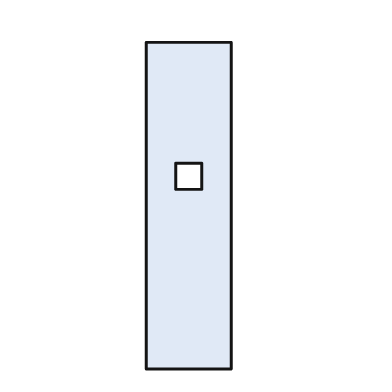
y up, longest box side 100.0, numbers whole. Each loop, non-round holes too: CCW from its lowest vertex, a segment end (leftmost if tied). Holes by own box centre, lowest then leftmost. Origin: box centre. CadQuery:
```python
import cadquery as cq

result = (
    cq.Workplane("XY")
    .moveTo(-13.0, -50.0)
    .lineTo(13.0, -50.0)
    .lineTo(13.0, 50.0)
    .lineTo(-13.0, 50.0)
    .close()
    .moveTo(-4.0, 5.0)
    .lineTo(4.0, 5.0)
    .lineTo(4.0, 13.0)
    .lineTo(-4.0, 13.0)
    .close()
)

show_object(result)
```